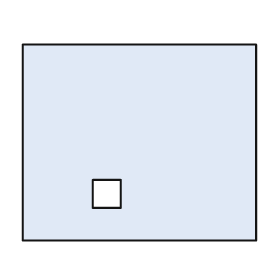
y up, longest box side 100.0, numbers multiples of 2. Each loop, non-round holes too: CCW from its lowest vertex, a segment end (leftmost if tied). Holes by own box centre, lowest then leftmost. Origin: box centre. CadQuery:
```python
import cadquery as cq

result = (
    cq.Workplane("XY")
    .moveTo(-50.0, -42.0)
    .lineTo(50.0, -42.0)
    .lineTo(50.0, 42.0)
    .lineTo(-50.0, 42.0)
    .close()
    .moveTo(-20.0, -28.0)
    .lineTo(-8.0, -28.0)
    .lineTo(-8.0, -16.0)
    .lineTo(-20.0, -16.0)
    .close()
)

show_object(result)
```